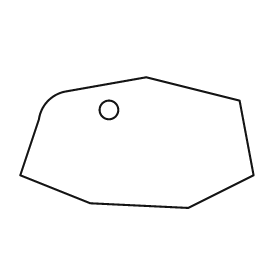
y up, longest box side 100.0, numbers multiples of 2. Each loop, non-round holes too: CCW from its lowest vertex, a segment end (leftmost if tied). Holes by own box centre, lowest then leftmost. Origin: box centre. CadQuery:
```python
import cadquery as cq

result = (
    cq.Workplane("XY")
    .moveTo(22.0, -28.0)
    .lineTo(50.0, -14.0)
    .lineTo(44.0, 18.0)
    .lineTo(4.0, 28.0)
    .lineTo(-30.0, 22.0)
    .threePointArc((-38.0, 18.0), (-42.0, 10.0))
    .lineTo(-50.0, -14.0)
    .lineTo(-20.0, -26.0)
    .close()
    .moveTo(-12.0, 14.0)
    .circle(4.0)
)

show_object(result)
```